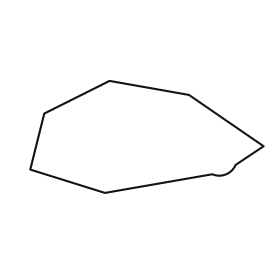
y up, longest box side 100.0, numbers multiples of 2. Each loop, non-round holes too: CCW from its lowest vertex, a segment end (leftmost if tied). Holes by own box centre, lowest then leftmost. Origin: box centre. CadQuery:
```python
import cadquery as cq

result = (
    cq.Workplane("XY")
    .moveTo(-18.0, -24.0)
    .lineTo(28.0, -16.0)
    .threePointArc((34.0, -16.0), (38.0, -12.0))
    .lineTo(50.0, -4.0)
    .lineTo(18.0, 18.0)
    .lineTo(-16.0, 24.0)
    .lineTo(-44.0, 10.0)
    .lineTo(-50.0, -14.0)
    .close()
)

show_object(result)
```